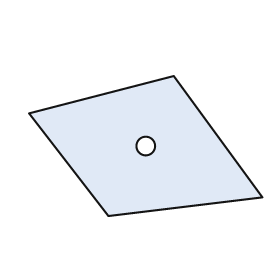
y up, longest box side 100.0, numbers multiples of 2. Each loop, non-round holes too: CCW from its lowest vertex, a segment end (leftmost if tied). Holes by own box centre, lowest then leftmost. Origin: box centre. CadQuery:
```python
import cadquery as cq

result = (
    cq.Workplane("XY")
    .moveTo(-16.0, -30.0)
    .lineTo(50.0, -22.0)
    .lineTo(12.0, 30.0)
    .lineTo(-50.0, 14.0)
    .close()
    .moveTo(0.0, 0.0)
    .circle(4.0)
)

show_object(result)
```